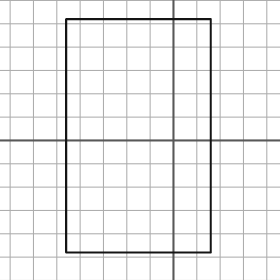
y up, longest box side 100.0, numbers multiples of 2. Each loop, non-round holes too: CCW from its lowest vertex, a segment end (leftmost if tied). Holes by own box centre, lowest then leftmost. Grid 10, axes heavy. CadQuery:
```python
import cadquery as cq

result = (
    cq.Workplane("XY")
    .moveTo(-46.0, -48.0)
    .lineTo(16.0, -48.0)
    .lineTo(16.0, 52.0)
    .lineTo(-46.0, 52.0)
    .close()
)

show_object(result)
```